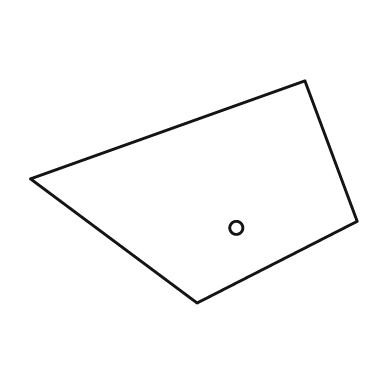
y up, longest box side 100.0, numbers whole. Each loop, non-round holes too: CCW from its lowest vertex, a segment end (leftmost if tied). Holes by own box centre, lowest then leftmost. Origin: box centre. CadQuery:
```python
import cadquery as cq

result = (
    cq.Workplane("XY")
    .moveTo(1.0, -34.0)
    .lineTo(50.0, -9.0)
    .lineTo(34.0, 34.0)
    .lineTo(-50.0, 4.0)
    .close()
    .moveTo(13.0, -11.0)
    .circle(2.0)
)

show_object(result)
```